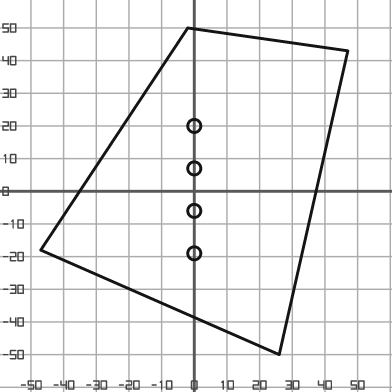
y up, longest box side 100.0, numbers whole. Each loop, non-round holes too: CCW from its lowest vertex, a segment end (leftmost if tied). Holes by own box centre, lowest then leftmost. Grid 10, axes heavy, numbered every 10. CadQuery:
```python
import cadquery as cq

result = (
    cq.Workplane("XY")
    .moveTo(26.0, -50.0)
    .lineTo(47.0, 43.0)
    .lineTo(-2.0, 50.0)
    .lineTo(-47.0, -18.0)
    .close()
    .moveTo(0.0, -19.0)
    .circle(2.0)
    .moveTo(0.0, -6.0)
    .circle(2.0)
    .moveTo(0.0, 7.0)
    .circle(2.0)
    .moveTo(0.0, 20.0)
    .circle(2.0)
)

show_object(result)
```